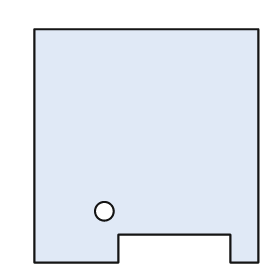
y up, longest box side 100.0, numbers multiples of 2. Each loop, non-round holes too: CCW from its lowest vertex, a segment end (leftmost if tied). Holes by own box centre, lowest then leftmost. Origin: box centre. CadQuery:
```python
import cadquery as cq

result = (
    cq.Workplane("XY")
    .moveTo(-48.0, -50.0)
    .lineTo(-12.0, -50.0)
    .lineTo(-12.0, -38.0)
    .lineTo(36.0, -38.0)
    .lineTo(36.0, -50.0)
    .lineTo(48.0, -50.0)
    .lineTo(48.0, 50.0)
    .lineTo(-48.0, 50.0)
    .close()
    .moveTo(-18.0, -28.0)
    .circle(4.0)
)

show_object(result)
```